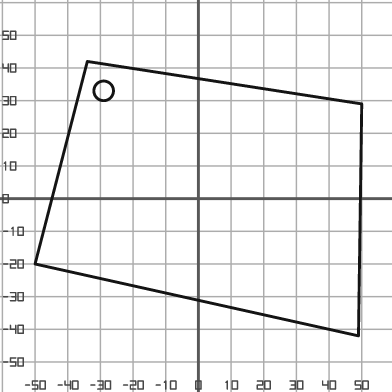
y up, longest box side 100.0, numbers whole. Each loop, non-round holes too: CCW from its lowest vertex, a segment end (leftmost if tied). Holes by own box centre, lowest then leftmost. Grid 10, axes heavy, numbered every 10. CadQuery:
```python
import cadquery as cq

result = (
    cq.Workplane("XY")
    .moveTo(49.0, -42.0)
    .lineTo(50.0, 29.0)
    .lineTo(-34.0, 42.0)
    .lineTo(-50.0, -20.0)
    .close()
    .moveTo(-29.0, 33.0)
    .circle(3.0)
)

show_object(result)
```